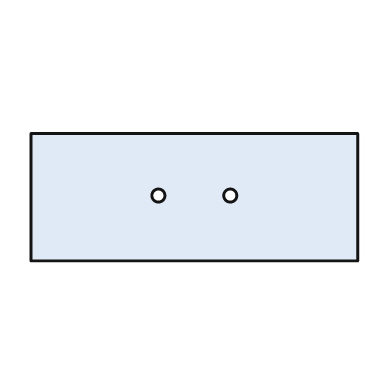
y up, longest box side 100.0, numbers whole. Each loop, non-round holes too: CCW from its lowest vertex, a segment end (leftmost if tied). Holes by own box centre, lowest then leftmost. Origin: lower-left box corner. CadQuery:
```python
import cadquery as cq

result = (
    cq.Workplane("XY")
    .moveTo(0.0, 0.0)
    .lineTo(100.0, 0.0)
    .lineTo(100.0, 39.0)
    .lineTo(0.0, 39.0)
    .close()
    .moveTo(39.0, 20.0)
    .circle(2.0)
    .moveTo(61.0, 20.0)
    .circle(2.0)
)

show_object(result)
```